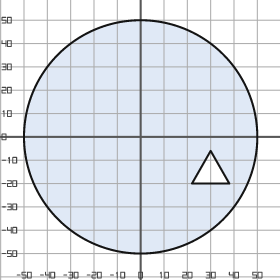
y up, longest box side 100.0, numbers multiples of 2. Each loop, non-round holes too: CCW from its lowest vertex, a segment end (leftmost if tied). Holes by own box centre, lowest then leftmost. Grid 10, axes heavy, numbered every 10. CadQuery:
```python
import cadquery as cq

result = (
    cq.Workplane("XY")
    .moveTo(0.0, 0.0)
    .circle(50.0)
    .moveTo(22.0, -20.0)
    .lineTo(38.0, -20.0)
    .lineTo(30.0, -6.0)
    .close()
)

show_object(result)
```